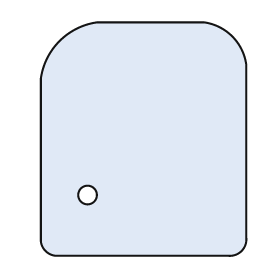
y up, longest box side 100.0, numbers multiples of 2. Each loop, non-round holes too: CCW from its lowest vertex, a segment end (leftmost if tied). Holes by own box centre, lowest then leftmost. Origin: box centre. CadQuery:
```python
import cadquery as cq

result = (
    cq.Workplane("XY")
    .moveTo(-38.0, -50.0)
    .lineTo(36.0, -50.0)
    .threePointArc((42.0, -48.0), (44.0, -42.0))
    .lineTo(44.0, 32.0)
    .threePointArc((38.0, 44.0), (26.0, 50.0))
    .lineTo(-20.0, 50.0)
    .threePointArc((-36.0, 42.0), (-44.0, 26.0))
    .lineTo(-44.0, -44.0)
    .threePointArc((-42.0, -48.0), (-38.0, -50.0))
    .close()
    .moveTo(-24.0, -24.0)
    .circle(4.0)
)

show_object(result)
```